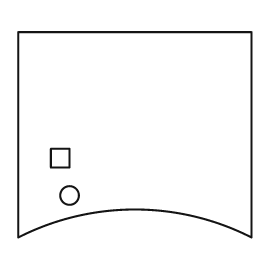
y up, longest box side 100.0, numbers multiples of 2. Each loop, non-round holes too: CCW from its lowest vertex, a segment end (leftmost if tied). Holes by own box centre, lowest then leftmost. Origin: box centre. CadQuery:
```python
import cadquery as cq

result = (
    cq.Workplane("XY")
    .moveTo(-50.0, -44.0)
    .threePointArc((0.0, -32.0), (50.0, -44.0))
    .lineTo(50.0, 44.0)
    .lineTo(-50.0, 44.0)
    .close()
    .moveTo(-28.0, -26.0)
    .circle(4.0)
    .moveTo(-36.0, -14.0)
    .lineTo(-28.0, -14.0)
    .lineTo(-28.0, -6.0)
    .lineTo(-36.0, -6.0)
    .close()
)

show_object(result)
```